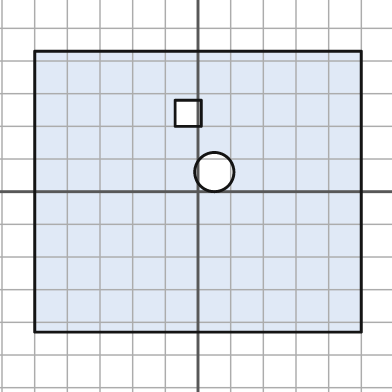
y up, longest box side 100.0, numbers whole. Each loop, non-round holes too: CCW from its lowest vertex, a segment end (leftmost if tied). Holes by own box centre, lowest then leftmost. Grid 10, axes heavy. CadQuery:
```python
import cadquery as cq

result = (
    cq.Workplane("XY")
    .moveTo(-50.0, -43.0)
    .lineTo(50.0, -43.0)
    .lineTo(50.0, 43.0)
    .lineTo(-50.0, 43.0)
    .close()
    .moveTo(5.0, 6.0)
    .circle(6.0)
    .moveTo(-7.0, 20.0)
    .lineTo(1.0, 20.0)
    .lineTo(1.0, 28.0)
    .lineTo(-7.0, 28.0)
    .close()
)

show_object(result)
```